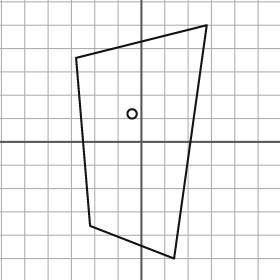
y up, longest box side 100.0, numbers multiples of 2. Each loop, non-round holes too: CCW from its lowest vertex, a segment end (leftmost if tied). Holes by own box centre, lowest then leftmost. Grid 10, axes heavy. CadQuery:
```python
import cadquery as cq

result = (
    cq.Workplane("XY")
    .moveTo(14.0, -50.0)
    .lineTo(28.0, 50.0)
    .lineTo(-28.0, 36.0)
    .lineTo(-22.0, -36.0)
    .close()
    .moveTo(-4.0, 12.0)
    .circle(2.0)
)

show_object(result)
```